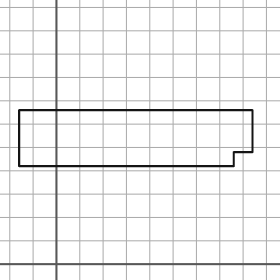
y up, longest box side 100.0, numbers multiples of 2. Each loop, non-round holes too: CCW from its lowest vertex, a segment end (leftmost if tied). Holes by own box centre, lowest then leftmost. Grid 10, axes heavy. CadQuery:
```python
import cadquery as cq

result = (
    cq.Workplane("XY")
    .moveTo(-16.0, 42.0)
    .lineTo(76.0, 42.0)
    .lineTo(76.0, 48.0)
    .lineTo(84.0, 48.0)
    .lineTo(84.0, 66.0)
    .lineTo(-16.0, 66.0)
    .close()
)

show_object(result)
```